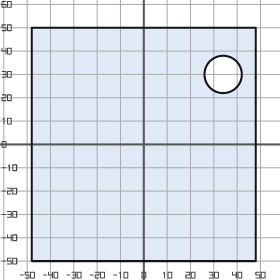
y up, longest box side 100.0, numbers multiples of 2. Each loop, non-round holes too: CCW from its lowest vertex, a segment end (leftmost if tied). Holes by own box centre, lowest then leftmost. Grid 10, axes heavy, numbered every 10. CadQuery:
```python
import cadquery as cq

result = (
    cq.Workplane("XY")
    .moveTo(-48.0, -50.0)
    .lineTo(48.0, -50.0)
    .lineTo(48.0, 50.0)
    .lineTo(-48.0, 50.0)
    .close()
    .moveTo(34.0, 30.0)
    .circle(8.0)
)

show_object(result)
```